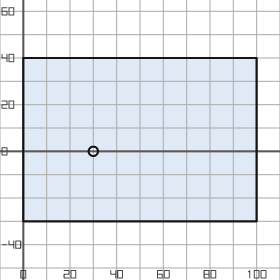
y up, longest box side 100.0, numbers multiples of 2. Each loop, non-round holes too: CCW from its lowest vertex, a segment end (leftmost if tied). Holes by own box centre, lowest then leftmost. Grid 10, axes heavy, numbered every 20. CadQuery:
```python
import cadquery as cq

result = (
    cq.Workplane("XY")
    .moveTo(0.0, -30.0)
    .lineTo(100.0, -30.0)
    .lineTo(100.0, 40.0)
    .lineTo(0.0, 40.0)
    .close()
    .moveTo(30.0, 0.0)
    .circle(2.0)
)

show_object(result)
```